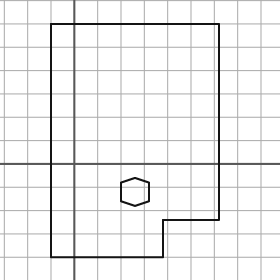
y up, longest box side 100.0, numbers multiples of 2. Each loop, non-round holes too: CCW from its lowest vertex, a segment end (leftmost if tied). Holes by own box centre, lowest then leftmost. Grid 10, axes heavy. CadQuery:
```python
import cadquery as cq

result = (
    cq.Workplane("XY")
    .moveTo(-10.0, -40.0)
    .lineTo(38.0, -40.0)
    .lineTo(38.0, -24.0)
    .lineTo(62.0, -24.0)
    .lineTo(62.0, 60.0)
    .lineTo(-10.0, 60.0)
    .close()
    .moveTo(26.0, -18.0)
    .lineTo(32.0, -16.0)
    .lineTo(32.0, -8.0)
    .lineTo(26.0, -6.0)
    .lineTo(20.0, -8.0)
    .lineTo(20.0, -16.0)
    .close()
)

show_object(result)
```